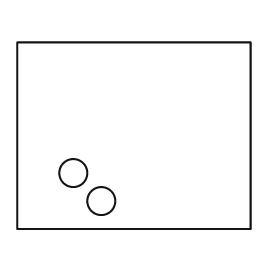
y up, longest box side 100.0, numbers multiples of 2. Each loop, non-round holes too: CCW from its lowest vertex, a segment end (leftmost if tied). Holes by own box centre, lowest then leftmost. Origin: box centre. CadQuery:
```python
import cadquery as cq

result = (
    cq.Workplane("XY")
    .moveTo(-50.0, -40.0)
    .lineTo(50.0, -40.0)
    .lineTo(50.0, 40.0)
    .lineTo(-50.0, 40.0)
    .close()
    .moveTo(-14.0, -28.0)
    .circle(6.0)
    .moveTo(-26.0, -16.0)
    .circle(6.0)
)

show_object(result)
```